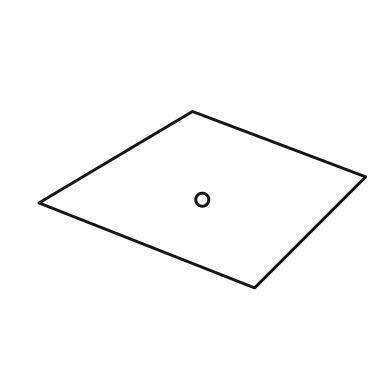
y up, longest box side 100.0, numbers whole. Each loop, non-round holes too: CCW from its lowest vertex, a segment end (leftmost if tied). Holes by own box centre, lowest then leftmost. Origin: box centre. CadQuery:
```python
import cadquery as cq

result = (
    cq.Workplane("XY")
    .moveTo(16.0, -27.0)
    .lineTo(50.0, 7.0)
    .lineTo(-3.0, 27.0)
    .lineTo(-50.0, -1.0)
    .close()
    .moveTo(0.0, 0.0)
    .circle(2.0)
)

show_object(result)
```